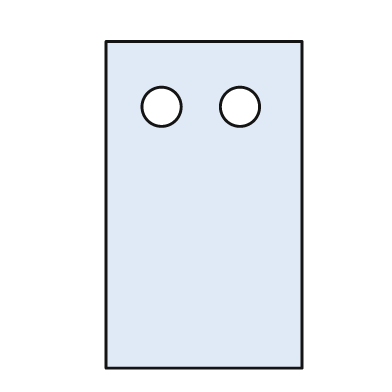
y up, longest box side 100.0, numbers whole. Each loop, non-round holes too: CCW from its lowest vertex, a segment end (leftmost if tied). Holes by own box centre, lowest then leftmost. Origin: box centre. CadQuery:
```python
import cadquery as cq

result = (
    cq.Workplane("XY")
    .moveTo(-30.0, -50.0)
    .lineTo(30.0, -50.0)
    .lineTo(30.0, 50.0)
    .lineTo(-30.0, 50.0)
    .close()
    .moveTo(-13.0, 30.0)
    .circle(6.0)
    .moveTo(11.0, 30.0)
    .circle(6.0)
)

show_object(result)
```